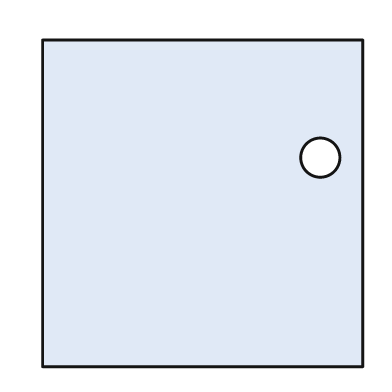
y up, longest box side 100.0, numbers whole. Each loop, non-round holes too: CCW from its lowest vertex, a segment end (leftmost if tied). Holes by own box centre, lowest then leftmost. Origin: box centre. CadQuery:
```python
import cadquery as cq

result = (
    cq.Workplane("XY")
    .moveTo(-49.0, -50.0)
    .lineTo(49.0, -50.0)
    .lineTo(49.0, 50.0)
    .lineTo(-49.0, 50.0)
    .close()
    .moveTo(36.0, 14.0)
    .circle(6.0)
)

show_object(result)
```